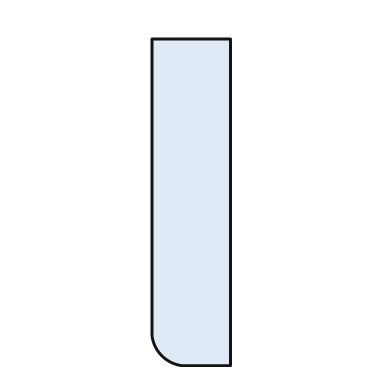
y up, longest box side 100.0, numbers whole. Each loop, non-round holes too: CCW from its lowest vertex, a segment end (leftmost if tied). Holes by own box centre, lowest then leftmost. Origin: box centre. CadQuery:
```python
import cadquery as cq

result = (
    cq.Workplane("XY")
    .moveTo(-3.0, -50.0)
    .lineTo(12.0, -50.0)
    .lineTo(12.0, 50.0)
    .lineTo(-12.0, 50.0)
    .lineTo(-12.0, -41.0)
    .threePointArc((-9.0, -47.0), (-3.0, -50.0))
    .close()
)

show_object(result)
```